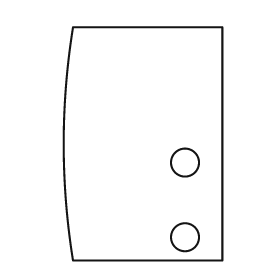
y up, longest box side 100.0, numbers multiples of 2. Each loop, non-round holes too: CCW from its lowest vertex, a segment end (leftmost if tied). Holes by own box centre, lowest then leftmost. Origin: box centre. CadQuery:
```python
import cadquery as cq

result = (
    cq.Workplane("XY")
    .moveTo(-30.0, -50.0)
    .lineTo(34.0, -50.0)
    .lineTo(34.0, 50.0)
    .lineTo(-30.0, 50.0)
    .threePointArc((-34.0, 0.0), (-30.0, -50.0))
    .close()
    .moveTo(18.0, -40.0)
    .circle(6.0)
    .moveTo(18.0, -8.0)
    .circle(6.0)
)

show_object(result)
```